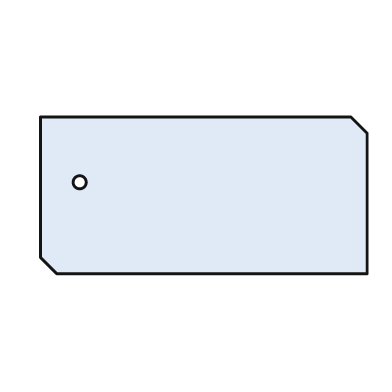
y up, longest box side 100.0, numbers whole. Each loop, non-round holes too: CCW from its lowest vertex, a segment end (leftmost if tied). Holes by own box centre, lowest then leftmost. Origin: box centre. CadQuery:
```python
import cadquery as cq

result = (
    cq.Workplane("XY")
    .moveTo(-45.0, -24.0)
    .lineTo(50.0, -24.0)
    .lineTo(50.0, 19.0)
    .lineTo(45.0, 24.0)
    .lineTo(-50.0, 24.0)
    .lineTo(-50.0, -19.0)
    .close()
    .moveTo(-38.0, 4.0)
    .circle(2.0)
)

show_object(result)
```